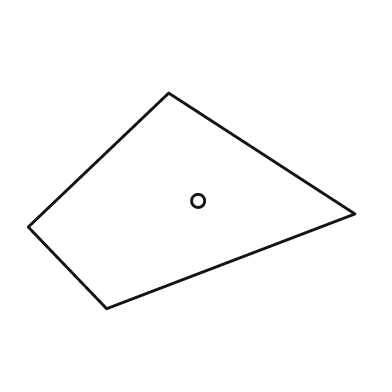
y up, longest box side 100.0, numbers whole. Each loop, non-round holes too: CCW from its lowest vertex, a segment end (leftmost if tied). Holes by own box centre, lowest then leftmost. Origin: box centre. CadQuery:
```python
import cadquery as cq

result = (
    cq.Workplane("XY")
    .moveTo(-26.0, -33.0)
    .lineTo(50.0, -4.0)
    .lineTo(-7.0, 33.0)
    .lineTo(-50.0, -8.0)
    .close()
    .moveTo(2.0, 0.0)
    .circle(2.0)
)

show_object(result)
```